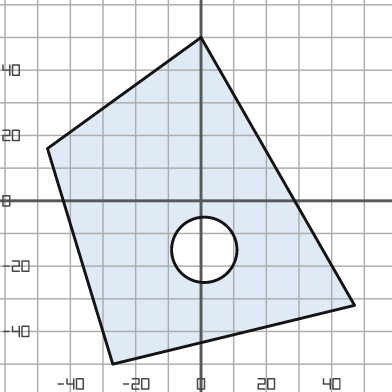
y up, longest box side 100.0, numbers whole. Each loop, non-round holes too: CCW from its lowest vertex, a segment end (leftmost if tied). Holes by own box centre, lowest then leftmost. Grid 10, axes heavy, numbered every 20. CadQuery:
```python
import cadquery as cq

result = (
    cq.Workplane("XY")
    .moveTo(-27.0, -50.0)
    .lineTo(47.0, -32.0)
    .lineTo(0.0, 50.0)
    .lineTo(-47.0, 16.0)
    .close()
    .moveTo(1.0, -15.0)
    .circle(10.0)
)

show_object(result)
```